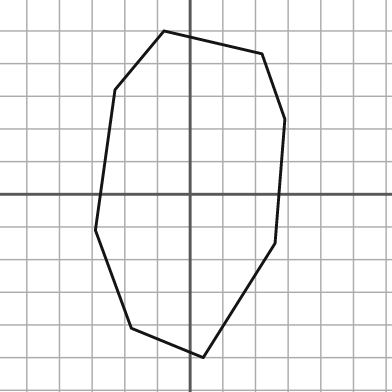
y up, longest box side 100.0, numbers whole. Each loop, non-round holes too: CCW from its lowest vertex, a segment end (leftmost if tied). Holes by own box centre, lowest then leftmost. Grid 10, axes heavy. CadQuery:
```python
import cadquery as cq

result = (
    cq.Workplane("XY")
    .moveTo(4.0, -50.0)
    .lineTo(26.0, -15.0)
    .lineTo(29.0, 23.0)
    .lineTo(22.0, 43.0)
    .lineTo(-8.0, 50.0)
    .lineTo(-23.0, 32.0)
    .lineTo(-29.0, -11.0)
    .lineTo(-18.0, -41.0)
    .close()
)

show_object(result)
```